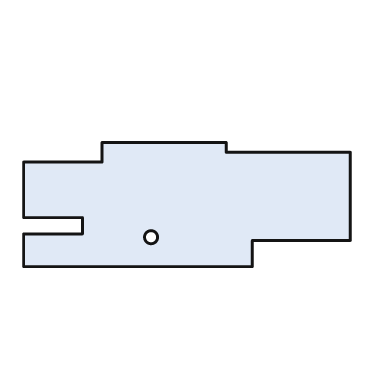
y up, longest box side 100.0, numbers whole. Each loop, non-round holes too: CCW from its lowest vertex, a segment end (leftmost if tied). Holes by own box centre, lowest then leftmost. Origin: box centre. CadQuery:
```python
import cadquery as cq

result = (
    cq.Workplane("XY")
    .moveTo(-50.0, -19.0)
    .lineTo(20.0, -19.0)
    .lineTo(20.0, -11.0)
    .lineTo(50.0, -11.0)
    .lineTo(50.0, 16.0)
    .lineTo(12.0, 16.0)
    .lineTo(12.0, 19.0)
    .lineTo(-26.0, 19.0)
    .lineTo(-26.0, 13.0)
    .lineTo(-50.0, 13.0)
    .lineTo(-50.0, -4.0)
    .lineTo(-32.0, -4.0)
    .lineTo(-32.0, -9.0)
    .lineTo(-50.0, -9.0)
    .close()
    .moveTo(-11.0, -10.0)
    .circle(2.0)
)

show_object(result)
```